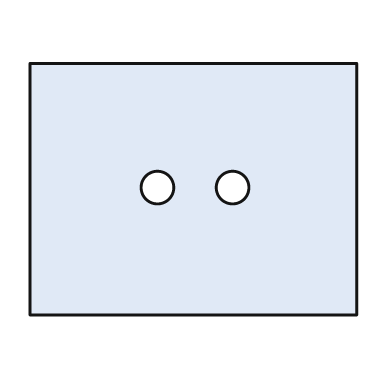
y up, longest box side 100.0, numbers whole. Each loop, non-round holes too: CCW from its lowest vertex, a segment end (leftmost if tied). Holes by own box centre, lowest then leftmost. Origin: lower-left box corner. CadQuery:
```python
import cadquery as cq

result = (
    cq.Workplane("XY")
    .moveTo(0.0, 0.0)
    .lineTo(100.0, 0.0)
    .lineTo(100.0, 77.0)
    .lineTo(0.0, 77.0)
    .close()
    .moveTo(39.0, 39.0)
    .circle(5.0)
    .moveTo(62.0, 39.0)
    .circle(5.0)
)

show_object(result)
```